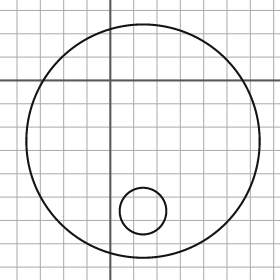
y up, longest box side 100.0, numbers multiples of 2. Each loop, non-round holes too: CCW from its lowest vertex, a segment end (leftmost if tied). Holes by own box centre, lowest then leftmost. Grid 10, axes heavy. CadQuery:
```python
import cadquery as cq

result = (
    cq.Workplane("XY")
    .moveTo(14.0, -26.0)
    .circle(50.0)
    .moveTo(14.0, -56.0)
    .circle(10.0)
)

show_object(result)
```